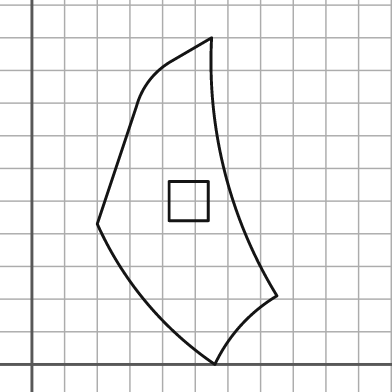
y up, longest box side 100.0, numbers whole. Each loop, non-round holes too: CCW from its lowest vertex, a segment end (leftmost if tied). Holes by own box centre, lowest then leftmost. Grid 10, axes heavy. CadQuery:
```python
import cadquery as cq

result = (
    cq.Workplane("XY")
    .moveTo(56.0, 0.0)
    .threePointArc((64.0, 12.0), (75.0, 21.0))
    .threePointArc((59.0, 59.0), (55.0, 100.0))
    .lineTo(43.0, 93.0)
    .threePointArc((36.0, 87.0), (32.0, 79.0))
    .lineTo(20.0, 43.0)
    .threePointArc((35.0, 19.0), (56.0, 0.0))
    .close()
    .moveTo(42.0, 44.0)
    .lineTo(54.0, 44.0)
    .lineTo(54.0, 56.0)
    .lineTo(42.0, 56.0)
    .close()
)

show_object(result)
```